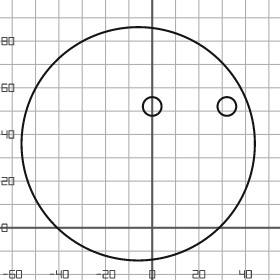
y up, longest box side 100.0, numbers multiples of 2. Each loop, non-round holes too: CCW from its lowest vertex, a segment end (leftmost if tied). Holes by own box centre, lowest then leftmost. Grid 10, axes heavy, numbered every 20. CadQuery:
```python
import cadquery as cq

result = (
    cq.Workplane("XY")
    .moveTo(-6.0, 36.0)
    .circle(50.0)
    .moveTo(0.0, 52.0)
    .circle(4.0)
    .moveTo(32.0, 52.0)
    .circle(4.0)
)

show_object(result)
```